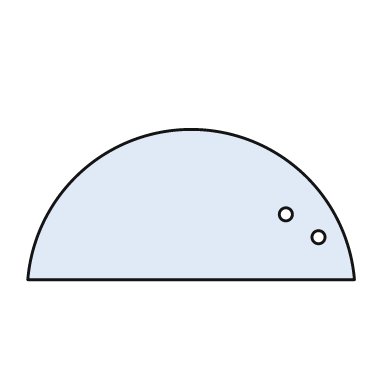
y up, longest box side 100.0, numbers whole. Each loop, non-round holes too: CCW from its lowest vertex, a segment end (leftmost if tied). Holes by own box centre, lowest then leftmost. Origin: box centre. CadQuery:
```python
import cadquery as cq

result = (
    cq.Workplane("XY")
    .moveTo(-50.0, -23.0)
    .lineTo(50.0, -23.0)
    .threePointArc((0.0, 23.0), (-50.0, -23.0))
    .close()
    .moveTo(39.0, -10.0)
    .circle(2.0)
    .moveTo(29.0, -3.0)
    .circle(2.0)
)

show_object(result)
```